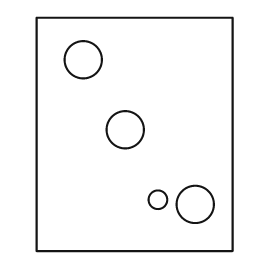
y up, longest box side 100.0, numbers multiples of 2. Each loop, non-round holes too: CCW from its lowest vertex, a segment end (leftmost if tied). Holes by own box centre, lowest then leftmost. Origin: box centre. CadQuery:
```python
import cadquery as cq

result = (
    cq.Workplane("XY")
    .moveTo(-42.0, -50.0)
    .lineTo(42.0, -50.0)
    .lineTo(42.0, 50.0)
    .lineTo(-42.0, 50.0)
    .close()
    .moveTo(26.0, -30.0)
    .circle(8.0)
    .moveTo(10.0, -28.0)
    .circle(4.0)
    .moveTo(-4.0, 2.0)
    .circle(8.0)
    .moveTo(-22.0, 32.0)
    .circle(8.0)
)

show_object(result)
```